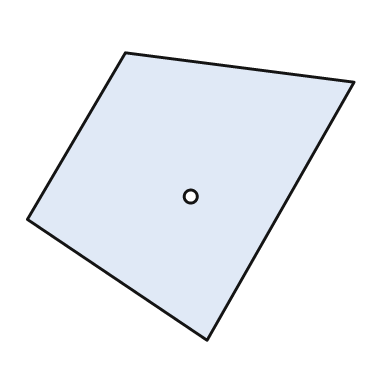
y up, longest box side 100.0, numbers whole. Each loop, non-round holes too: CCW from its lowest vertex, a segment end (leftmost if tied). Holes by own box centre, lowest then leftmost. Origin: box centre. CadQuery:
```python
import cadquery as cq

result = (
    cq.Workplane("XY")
    .moveTo(5.0, -44.0)
    .lineTo(50.0, 35.0)
    .lineTo(-20.0, 44.0)
    .lineTo(-50.0, -7.0)
    .close()
    .moveTo(0.0, 0.0)
    .circle(2.0)
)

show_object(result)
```